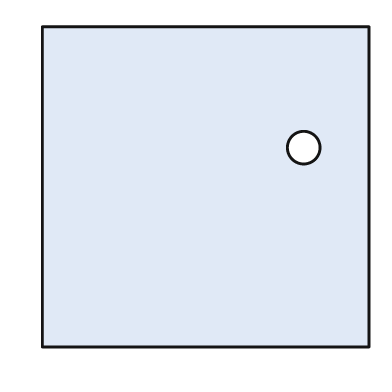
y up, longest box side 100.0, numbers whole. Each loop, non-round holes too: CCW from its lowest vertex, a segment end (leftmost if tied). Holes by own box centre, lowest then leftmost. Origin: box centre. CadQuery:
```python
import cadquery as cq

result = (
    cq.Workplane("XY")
    .moveTo(-50.0, -49.0)
    .lineTo(50.0, -49.0)
    .lineTo(50.0, 49.0)
    .lineTo(-50.0, 49.0)
    .close()
    .moveTo(30.0, 12.0)
    .circle(5.0)
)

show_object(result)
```